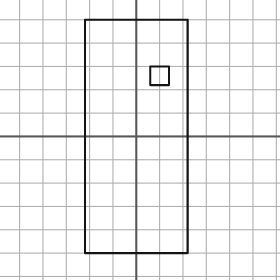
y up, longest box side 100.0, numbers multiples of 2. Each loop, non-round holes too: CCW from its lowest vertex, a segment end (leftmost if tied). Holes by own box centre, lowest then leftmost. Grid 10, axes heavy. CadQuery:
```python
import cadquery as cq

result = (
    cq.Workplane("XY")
    .moveTo(-22.0, -50.0)
    .lineTo(22.0, -50.0)
    .lineTo(22.0, 50.0)
    .lineTo(-22.0, 50.0)
    .close()
    .moveTo(6.0, 22.0)
    .lineTo(14.0, 22.0)
    .lineTo(14.0, 30.0)
    .lineTo(6.0, 30.0)
    .close()
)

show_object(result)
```